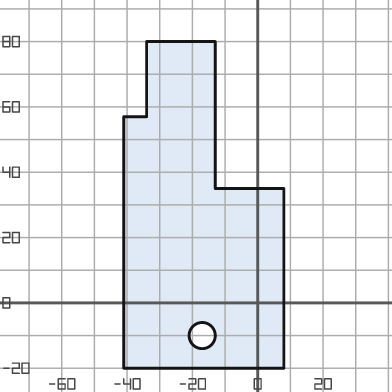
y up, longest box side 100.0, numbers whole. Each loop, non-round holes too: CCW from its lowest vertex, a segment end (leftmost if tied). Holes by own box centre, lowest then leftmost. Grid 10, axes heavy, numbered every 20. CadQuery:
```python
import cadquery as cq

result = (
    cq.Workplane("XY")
    .moveTo(-41.0, -20.0)
    .lineTo(8.0, -20.0)
    .lineTo(8.0, 35.0)
    .lineTo(-13.0, 35.0)
    .lineTo(-13.0, 80.0)
    .lineTo(-34.0, 80.0)
    .lineTo(-34.0, 57.0)
    .lineTo(-41.0, 57.0)
    .close()
    .moveTo(-17.0, -10.0)
    .circle(4.0)
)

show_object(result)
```